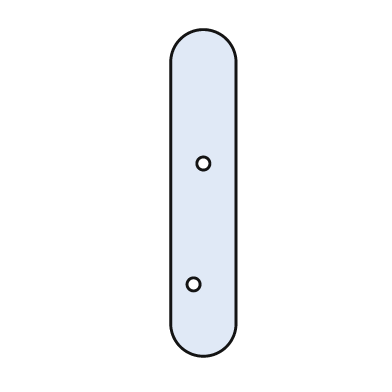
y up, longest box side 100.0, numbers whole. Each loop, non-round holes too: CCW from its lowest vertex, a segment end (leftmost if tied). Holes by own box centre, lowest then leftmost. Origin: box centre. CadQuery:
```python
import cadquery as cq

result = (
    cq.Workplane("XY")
    .moveTo(-10.0, -40.0)
    .threePointArc((0.0, -50.0), (10.0, -40.0))
    .lineTo(10.0, 40.0)
    .threePointArc((0.0, 50.0), (-10.0, 40.0))
    .close()
    .moveTo(-3.0, -28.0)
    .circle(2.0)
    .moveTo(0.0, 9.0)
    .circle(2.0)
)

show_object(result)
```